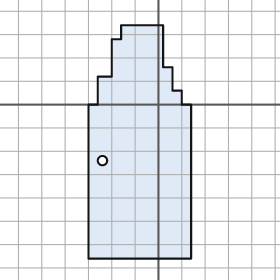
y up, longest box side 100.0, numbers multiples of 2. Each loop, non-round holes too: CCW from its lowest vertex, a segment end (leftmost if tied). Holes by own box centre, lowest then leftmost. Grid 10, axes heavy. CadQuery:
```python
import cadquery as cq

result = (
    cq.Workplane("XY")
    .moveTo(-30.0, -66.0)
    .lineTo(14.0, -66.0)
    .lineTo(14.0, 0.0)
    .lineTo(10.0, 0.0)
    .lineTo(10.0, 6.0)
    .lineTo(6.0, 6.0)
    .lineTo(6.0, 16.0)
    .lineTo(2.0, 16.0)
    .lineTo(2.0, 34.0)
    .lineTo(-16.0, 34.0)
    .lineTo(-16.0, 28.0)
    .lineTo(-20.0, 28.0)
    .lineTo(-20.0, 12.0)
    .lineTo(-26.0, 12.0)
    .lineTo(-26.0, 0.0)
    .lineTo(-30.0, 0.0)
    .close()
    .moveTo(-24.0, -24.0)
    .circle(2.0)
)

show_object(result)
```